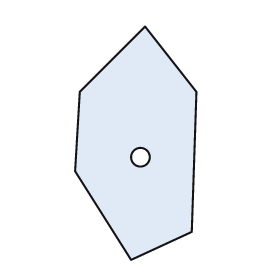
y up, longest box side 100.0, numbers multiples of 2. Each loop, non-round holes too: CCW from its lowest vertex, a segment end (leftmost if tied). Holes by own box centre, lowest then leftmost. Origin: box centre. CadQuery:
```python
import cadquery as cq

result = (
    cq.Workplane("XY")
    .moveTo(-2.0, -50.0)
    .lineTo(24.0, -38.0)
    .lineTo(26.0, 22.0)
    .lineTo(4.0, 50.0)
    .lineTo(-24.0, 22.0)
    .lineTo(-26.0, -12.0)
    .close()
    .moveTo(2.0, -6.0)
    .circle(4.0)
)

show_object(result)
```